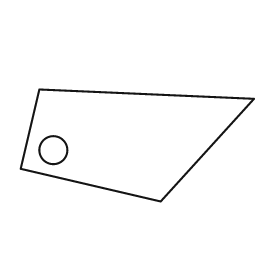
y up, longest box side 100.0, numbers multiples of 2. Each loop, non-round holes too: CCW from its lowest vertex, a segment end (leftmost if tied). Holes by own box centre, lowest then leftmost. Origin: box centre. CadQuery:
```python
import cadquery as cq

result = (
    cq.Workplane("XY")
    .moveTo(10.0, -24.0)
    .lineTo(50.0, 20.0)
    .lineTo(-42.0, 24.0)
    .lineTo(-50.0, -10.0)
    .close()
    .moveTo(-36.0, -2.0)
    .circle(6.0)
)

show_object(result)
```